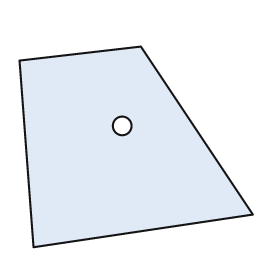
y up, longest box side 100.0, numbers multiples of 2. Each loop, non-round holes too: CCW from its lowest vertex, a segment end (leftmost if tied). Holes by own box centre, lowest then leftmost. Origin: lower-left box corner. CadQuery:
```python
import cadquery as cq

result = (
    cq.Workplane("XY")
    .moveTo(6.0, 0.0)
    .lineTo(100.0, 14.0)
    .lineTo(52.0, 86.0)
    .lineTo(0.0, 80.0)
    .close()
    .moveTo(44.0, 52.0)
    .circle(4.0)
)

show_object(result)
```